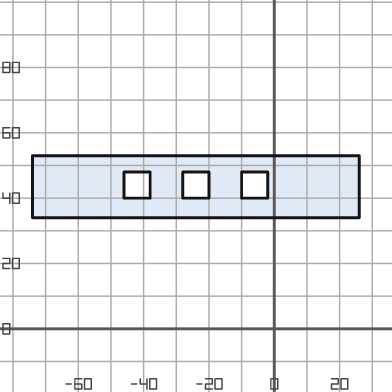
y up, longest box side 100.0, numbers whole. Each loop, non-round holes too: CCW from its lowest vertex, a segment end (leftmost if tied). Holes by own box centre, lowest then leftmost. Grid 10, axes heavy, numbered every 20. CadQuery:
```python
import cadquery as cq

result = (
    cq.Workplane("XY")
    .moveTo(-74.0, 34.0)
    .lineTo(26.0, 34.0)
    .lineTo(26.0, 53.0)
    .lineTo(-74.0, 53.0)
    .close()
    .moveTo(-46.0, 40.0)
    .lineTo(-38.0, 40.0)
    .lineTo(-38.0, 48.0)
    .lineTo(-46.0, 48.0)
    .close()
    .moveTo(-28.0, 40.0)
    .lineTo(-20.0, 40.0)
    .lineTo(-20.0, 48.0)
    .lineTo(-28.0, 48.0)
    .close()
    .moveTo(-10.0, 40.0)
    .lineTo(-2.0, 40.0)
    .lineTo(-2.0, 48.0)
    .lineTo(-10.0, 48.0)
    .close()
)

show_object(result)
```